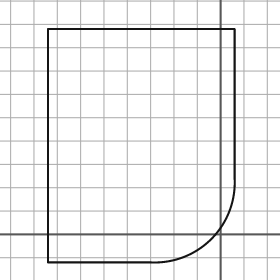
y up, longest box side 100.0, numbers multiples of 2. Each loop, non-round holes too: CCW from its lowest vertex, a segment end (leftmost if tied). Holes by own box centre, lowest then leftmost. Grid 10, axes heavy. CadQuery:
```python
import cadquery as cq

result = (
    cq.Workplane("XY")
    .moveTo(-74.0, -12.0)
    .lineTo(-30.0, -12.0)
    .threePointArc((-4.0, -2.0), (6.0, 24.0))
    .lineTo(6.0, 88.0)
    .lineTo(-74.0, 88.0)
    .close()
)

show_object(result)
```